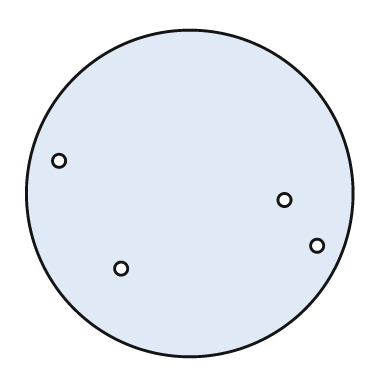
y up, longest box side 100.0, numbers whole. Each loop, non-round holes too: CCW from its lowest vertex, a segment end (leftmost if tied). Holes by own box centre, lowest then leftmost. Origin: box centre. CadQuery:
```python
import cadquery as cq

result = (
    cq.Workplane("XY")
    .moveTo(0.0, 0.0)
    .circle(50.0)
    .moveTo(-21.0, -23.0)
    .circle(2.0)
    .moveTo(39.0, -16.0)
    .circle(2.0)
    .moveTo(29.0, -2.0)
    .circle(2.0)
    .moveTo(-40.0, 10.0)
    .circle(2.0)
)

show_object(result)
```